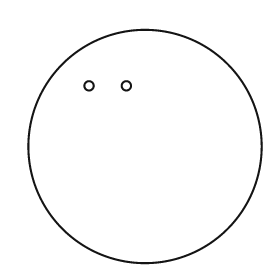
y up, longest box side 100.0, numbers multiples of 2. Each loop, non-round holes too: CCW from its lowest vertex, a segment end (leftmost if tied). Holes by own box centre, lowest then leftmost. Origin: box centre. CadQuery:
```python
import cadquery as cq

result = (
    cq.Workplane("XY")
    .moveTo(0.0, 0.0)
    .circle(50.0)
    .moveTo(-24.0, 26.0)
    .circle(2.0)
    .moveTo(-8.0, 26.0)
    .circle(2.0)
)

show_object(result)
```